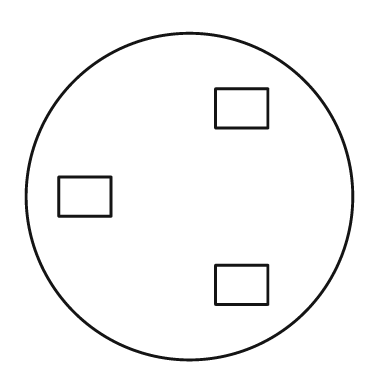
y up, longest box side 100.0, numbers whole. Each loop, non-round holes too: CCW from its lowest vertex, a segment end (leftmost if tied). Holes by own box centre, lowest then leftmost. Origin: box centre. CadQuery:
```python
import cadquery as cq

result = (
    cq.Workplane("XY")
    .moveTo(0.0, 0.0)
    .circle(50.0)
    .moveTo(8.0, -33.0)
    .lineTo(24.0, -33.0)
    .lineTo(24.0, -21.0)
    .lineTo(8.0, -21.0)
    .close()
    .moveTo(-40.0, -6.0)
    .lineTo(-24.0, -6.0)
    .lineTo(-24.0, 6.0)
    .lineTo(-40.0, 6.0)
    .close()
    .moveTo(8.0, 21.0)
    .lineTo(24.0, 21.0)
    .lineTo(24.0, 33.0)
    .lineTo(8.0, 33.0)
    .close()
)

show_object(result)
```